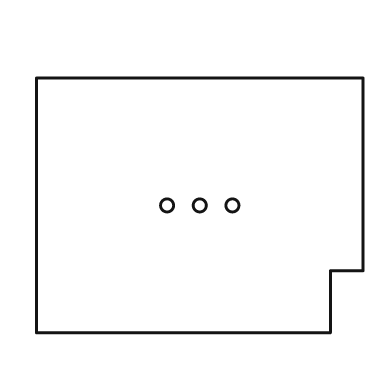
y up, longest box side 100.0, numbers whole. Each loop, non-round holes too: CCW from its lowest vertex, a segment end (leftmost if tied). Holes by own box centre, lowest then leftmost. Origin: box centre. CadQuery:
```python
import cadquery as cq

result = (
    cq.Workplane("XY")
    .moveTo(-50.0, -39.0)
    .lineTo(40.0, -39.0)
    .lineTo(40.0, -20.0)
    .lineTo(50.0, -20.0)
    .lineTo(50.0, 39.0)
    .lineTo(-50.0, 39.0)
    .close()
    .moveTo(-10.0, 0.0)
    .circle(2.0)
    .moveTo(0.0, 0.0)
    .circle(2.0)
    .moveTo(10.0, 0.0)
    .circle(2.0)
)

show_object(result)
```